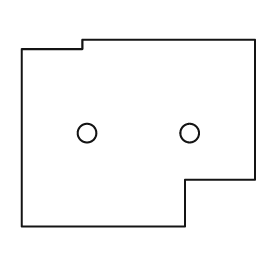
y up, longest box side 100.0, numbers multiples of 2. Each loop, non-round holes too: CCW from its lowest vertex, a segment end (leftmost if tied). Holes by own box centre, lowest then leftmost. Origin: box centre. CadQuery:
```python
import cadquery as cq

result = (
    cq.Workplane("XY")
    .moveTo(-50.0, -40.0)
    .lineTo(20.0, -40.0)
    .lineTo(20.0, -20.0)
    .lineTo(50.0, -20.0)
    .lineTo(50.0, 40.0)
    .lineTo(-24.0, 40.0)
    .lineTo(-24.0, 36.0)
    .lineTo(-50.0, 36.0)
    .close()
    .moveTo(-22.0, 0.0)
    .circle(4.0)
    .moveTo(22.0, 0.0)
    .circle(4.0)
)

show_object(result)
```